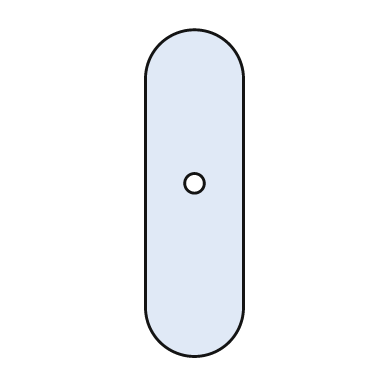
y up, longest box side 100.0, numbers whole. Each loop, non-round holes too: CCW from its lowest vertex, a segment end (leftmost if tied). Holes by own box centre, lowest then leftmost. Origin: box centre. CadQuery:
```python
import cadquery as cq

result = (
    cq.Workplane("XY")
    .moveTo(-15.0, -35.0)
    .threePointArc((0.0, -50.0), (15.0, -35.0))
    .lineTo(15.0, 35.0)
    .threePointArc((0.0, 50.0), (-15.0, 35.0))
    .close()
    .moveTo(0.0, 3.0)
    .circle(3.0)
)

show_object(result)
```